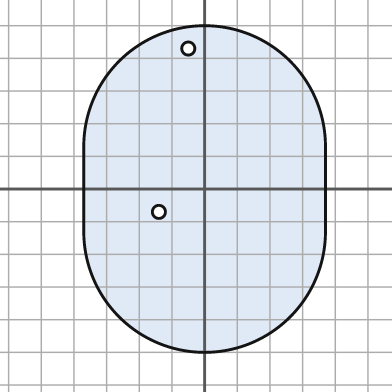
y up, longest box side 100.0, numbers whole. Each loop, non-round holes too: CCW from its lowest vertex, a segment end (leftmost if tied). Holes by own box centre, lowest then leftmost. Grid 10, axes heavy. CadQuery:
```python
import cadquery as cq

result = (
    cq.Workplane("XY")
    .moveTo(-37.0, -13.0)
    .threePointArc((0.0, -50.0), (37.0, -13.0))
    .lineTo(37.0, 13.0)
    .threePointArc((0.0, 50.0), (-37.0, 13.0))
    .close()
    .moveTo(-14.0, -7.0)
    .circle(2.0)
    .moveTo(-5.0, 43.0)
    .circle(2.0)
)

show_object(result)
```